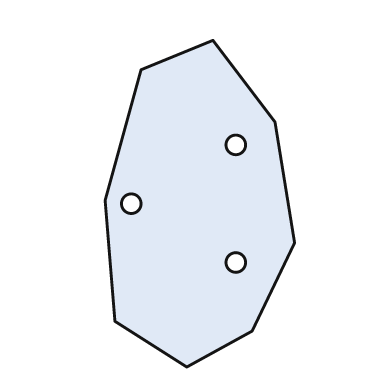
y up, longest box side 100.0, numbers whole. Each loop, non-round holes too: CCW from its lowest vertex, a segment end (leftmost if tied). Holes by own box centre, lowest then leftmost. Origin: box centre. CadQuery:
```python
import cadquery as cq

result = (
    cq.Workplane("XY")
    .moveTo(-4.0, -50.0)
    .lineTo(16.0, -39.0)
    .lineTo(29.0, -12.0)
    .lineTo(23.0, 25.0)
    .lineTo(4.0, 50.0)
    .lineTo(-18.0, 41.0)
    .lineTo(-29.0, 1.0)
    .lineTo(-26.0, -36.0)
    .close()
    .moveTo(11.0, -18.0)
    .circle(3.0)
    .moveTo(-21.0, 0.0)
    .circle(3.0)
    .moveTo(11.0, 18.0)
    .circle(3.0)
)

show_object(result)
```